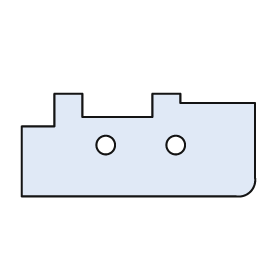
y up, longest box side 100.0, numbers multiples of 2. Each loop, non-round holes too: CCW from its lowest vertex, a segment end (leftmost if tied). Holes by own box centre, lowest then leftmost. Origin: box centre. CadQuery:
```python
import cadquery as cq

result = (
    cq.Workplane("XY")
    .moveTo(-50.0, -22.0)
    .lineTo(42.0, -22.0)
    .threePointArc((48.0, -20.0), (50.0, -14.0))
    .lineTo(50.0, 18.0)
    .lineTo(18.0, 18.0)
    .lineTo(18.0, 22.0)
    .lineTo(6.0, 22.0)
    .lineTo(6.0, 12.0)
    .lineTo(-24.0, 12.0)
    .lineTo(-24.0, 22.0)
    .lineTo(-36.0, 22.0)
    .lineTo(-36.0, 8.0)
    .lineTo(-50.0, 8.0)
    .close()
    .moveTo(-14.0, 0.0)
    .circle(4.0)
    .moveTo(16.0, 0.0)
    .circle(4.0)
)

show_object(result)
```